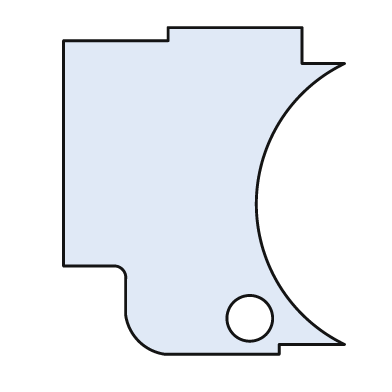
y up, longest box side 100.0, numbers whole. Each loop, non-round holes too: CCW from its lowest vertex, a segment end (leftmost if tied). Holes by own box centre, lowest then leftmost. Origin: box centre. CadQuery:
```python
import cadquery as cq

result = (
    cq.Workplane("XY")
    .moveTo(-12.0, -50.0)
    .lineTo(23.0, -50.0)
    .lineTo(23.0, -47.0)
    .lineTo(43.0, -47.0)
    .threePointArc((16.0, -4.0), (43.0, 39.0))
    .lineTo(30.0, 39.0)
    .lineTo(30.0, 50.0)
    .lineTo(-11.0, 50.0)
    .lineTo(-11.0, 46.0)
    .lineTo(-43.0, 46.0)
    .lineTo(-43.0, -23.0)
    .lineTo(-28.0, -23.0)
    .threePointArc((-25.0, -24.0), (-24.0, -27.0))
    .lineTo(-24.0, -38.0)
    .threePointArc((-20.0, -46.0), (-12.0, -50.0))
    .close()
    .moveTo(14.0, -39.0)
    .circle(7.0)
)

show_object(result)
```